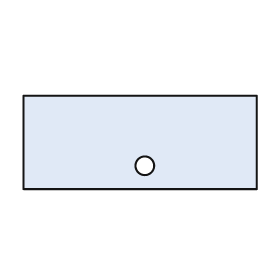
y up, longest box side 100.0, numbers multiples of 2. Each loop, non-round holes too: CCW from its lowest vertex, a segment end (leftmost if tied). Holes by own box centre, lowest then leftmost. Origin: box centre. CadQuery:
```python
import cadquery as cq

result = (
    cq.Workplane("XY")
    .moveTo(-50.0, -20.0)
    .lineTo(50.0, -20.0)
    .lineTo(50.0, 20.0)
    .lineTo(-50.0, 20.0)
    .close()
    .moveTo(2.0, -10.0)
    .circle(4.0)
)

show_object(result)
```